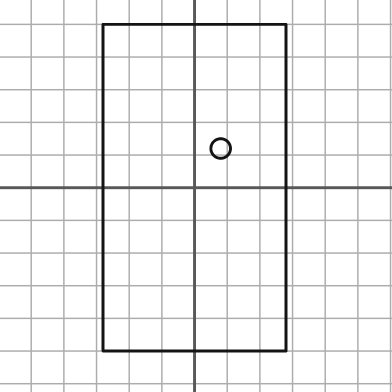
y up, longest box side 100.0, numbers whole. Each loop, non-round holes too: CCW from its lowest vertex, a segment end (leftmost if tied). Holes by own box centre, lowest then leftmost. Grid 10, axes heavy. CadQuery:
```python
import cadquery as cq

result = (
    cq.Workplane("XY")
    .moveTo(-28.0, -50.0)
    .lineTo(28.0, -50.0)
    .lineTo(28.0, 50.0)
    .lineTo(-28.0, 50.0)
    .close()
    .moveTo(8.0, 12.0)
    .circle(3.0)
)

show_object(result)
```